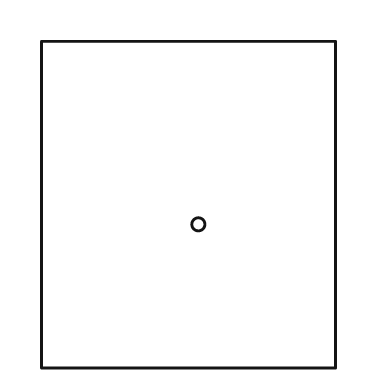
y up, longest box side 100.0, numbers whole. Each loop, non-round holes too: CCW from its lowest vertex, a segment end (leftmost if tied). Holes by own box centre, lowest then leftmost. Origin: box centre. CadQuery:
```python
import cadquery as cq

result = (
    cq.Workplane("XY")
    .moveTo(-45.0, -50.0)
    .lineTo(45.0, -50.0)
    .lineTo(45.0, 50.0)
    .lineTo(-45.0, 50.0)
    .close()
    .moveTo(3.0, -6.0)
    .circle(2.0)
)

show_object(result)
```